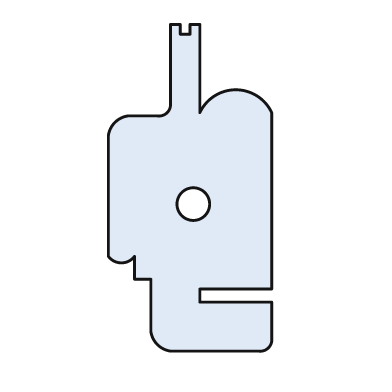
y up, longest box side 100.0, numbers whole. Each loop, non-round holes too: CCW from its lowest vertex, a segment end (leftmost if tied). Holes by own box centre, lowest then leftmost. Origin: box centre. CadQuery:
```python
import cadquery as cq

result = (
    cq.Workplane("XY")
    .moveTo(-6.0, -50.0)
    .lineTo(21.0, -50.0)
    .threePointArc((24.0, -49.0), (25.0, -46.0))
    .lineTo(25.0, -35.0)
    .lineTo(3.0, -35.0)
    .lineTo(3.0, -31.0)
    .lineTo(25.0, -31.0)
    .lineTo(25.0, 23.0)
    .threePointArc((14.0, 30.0), (3.0, 23.0))
    .lineTo(3.0, 50.0)
    .lineTo(0.0, 50.0)
    .lineTo(0.0, 47.0)
    .lineTo(-3.0, 47.0)
    .lineTo(-3.0, 50.0)
    .lineTo(-6.0, 50.0)
    .lineTo(-6.0, 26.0)
    .threePointArc((-7.0, 23.0), (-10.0, 22.0))
    .lineTo(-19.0, 22.0)
    .threePointArc((-23.0, 20.0), (-25.0, 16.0))
    .lineTo(-25.0, -21.0)
    .threePointArc((-21.0, -23.0), (-17.0, -21.0))
    .lineTo(-17.0, -28.0)
    .lineTo(-12.0, -28.0)
    .lineTo(-12.0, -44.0)
    .threePointArc((-10.0, -48.0), (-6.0, -50.0))
    .close()
    .moveTo(1.0, -5.0)
    .circle(5.0)
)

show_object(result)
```